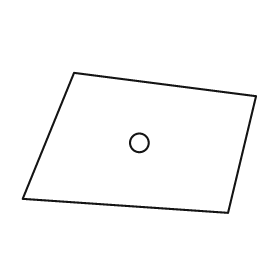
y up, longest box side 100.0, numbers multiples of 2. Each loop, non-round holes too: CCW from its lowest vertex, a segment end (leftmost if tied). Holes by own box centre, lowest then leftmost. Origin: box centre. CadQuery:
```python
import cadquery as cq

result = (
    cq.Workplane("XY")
    .moveTo(38.0, -30.0)
    .lineTo(50.0, 20.0)
    .lineTo(-28.0, 30.0)
    .lineTo(-50.0, -24.0)
    .close()
    .moveTo(0.0, 0.0)
    .circle(4.0)
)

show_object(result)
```